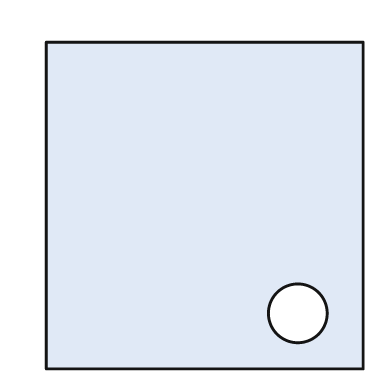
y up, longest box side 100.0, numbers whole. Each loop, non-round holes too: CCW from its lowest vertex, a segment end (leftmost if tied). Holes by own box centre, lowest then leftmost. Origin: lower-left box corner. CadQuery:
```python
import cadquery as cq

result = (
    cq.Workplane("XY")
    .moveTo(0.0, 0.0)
    .lineTo(97.0, 0.0)
    .lineTo(97.0, 100.0)
    .lineTo(0.0, 100.0)
    .close()
    .moveTo(77.0, 17.0)
    .circle(9.0)
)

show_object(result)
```